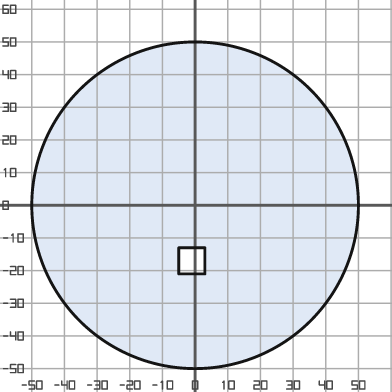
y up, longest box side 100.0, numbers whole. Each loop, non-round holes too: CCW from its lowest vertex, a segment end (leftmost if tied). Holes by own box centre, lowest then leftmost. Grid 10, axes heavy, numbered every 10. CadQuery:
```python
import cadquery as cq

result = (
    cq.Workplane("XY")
    .moveTo(0.0, 0.0)
    .circle(50.0)
    .moveTo(-5.0, -21.0)
    .lineTo(3.0, -21.0)
    .lineTo(3.0, -13.0)
    .lineTo(-5.0, -13.0)
    .close()
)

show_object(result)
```